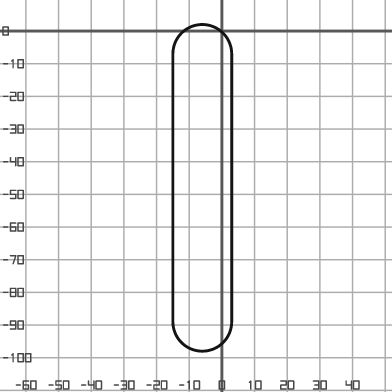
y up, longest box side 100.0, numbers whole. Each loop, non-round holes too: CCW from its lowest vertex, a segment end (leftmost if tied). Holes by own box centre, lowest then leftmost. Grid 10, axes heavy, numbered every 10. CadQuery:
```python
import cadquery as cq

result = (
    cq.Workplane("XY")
    .moveTo(-15.0, -89.0)
    .threePointArc((-6.0, -98.0), (3.0, -89.0))
    .lineTo(3.0, -7.0)
    .threePointArc((-6.0, 2.0), (-15.0, -7.0))
    .close()
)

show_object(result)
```